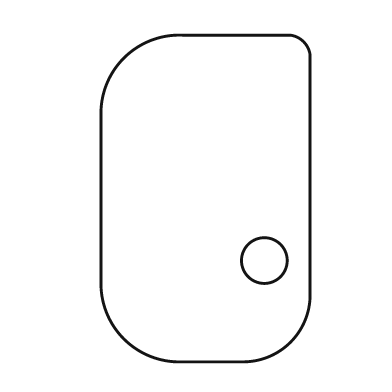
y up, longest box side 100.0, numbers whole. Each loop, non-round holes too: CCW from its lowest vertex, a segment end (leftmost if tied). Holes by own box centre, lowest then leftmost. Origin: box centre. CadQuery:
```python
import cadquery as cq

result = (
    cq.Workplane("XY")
    .moveTo(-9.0, -50.0)
    .lineTo(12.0, -50.0)
    .threePointArc((26.0, -44.0), (32.0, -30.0))
    .lineTo(32.0, 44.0)
    .threePointArc((30.0, 48.0), (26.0, 50.0))
    .lineTo(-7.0, 50.0)
    .threePointArc((-25.0, 43.0), (-32.0, 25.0))
    .lineTo(-32.0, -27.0)
    .threePointArc((-25.0, -43.0), (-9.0, -50.0))
    .close()
    .moveTo(18.0, -19.0)
    .circle(7.0)
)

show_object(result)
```